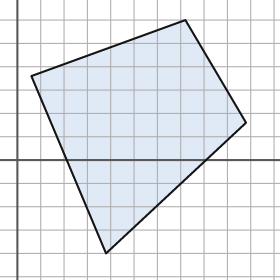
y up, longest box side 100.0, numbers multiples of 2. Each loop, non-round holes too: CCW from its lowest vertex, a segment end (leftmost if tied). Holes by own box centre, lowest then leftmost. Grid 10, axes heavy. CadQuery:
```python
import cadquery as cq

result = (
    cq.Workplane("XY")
    .moveTo(38.0, -40.0)
    .lineTo(98.0, 16.0)
    .lineTo(72.0, 60.0)
    .lineTo(6.0, 36.0)
    .close()
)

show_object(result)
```